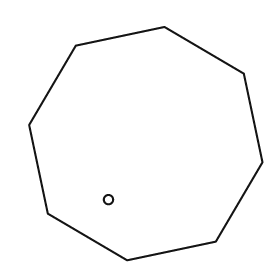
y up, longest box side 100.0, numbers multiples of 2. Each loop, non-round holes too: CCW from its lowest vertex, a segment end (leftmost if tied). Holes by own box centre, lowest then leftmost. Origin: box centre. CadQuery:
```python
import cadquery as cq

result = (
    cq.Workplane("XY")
    .moveTo(-8.0, -50.0)
    .lineTo(30.0, -42.0)
    .lineTo(50.0, -8.0)
    .lineTo(42.0, 30.0)
    .lineTo(8.0, 50.0)
    .lineTo(-30.0, 42.0)
    .lineTo(-50.0, 8.0)
    .lineTo(-42.0, -30.0)
    .close()
    .moveTo(-16.0, -24.0)
    .circle(2.0)
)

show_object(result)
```